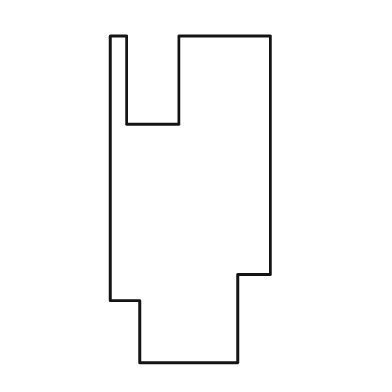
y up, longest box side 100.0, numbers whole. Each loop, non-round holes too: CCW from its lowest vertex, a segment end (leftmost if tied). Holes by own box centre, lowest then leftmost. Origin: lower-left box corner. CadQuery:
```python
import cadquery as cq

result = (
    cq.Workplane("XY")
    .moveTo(9.0, 0.0)
    .lineTo(39.0, 0.0)
    .lineTo(39.0, 27.0)
    .lineTo(49.0, 27.0)
    .lineTo(49.0, 100.0)
    .lineTo(21.0, 100.0)
    .lineTo(21.0, 73.0)
    .lineTo(5.0, 73.0)
    .lineTo(5.0, 100.0)
    .lineTo(0.0, 100.0)
    .lineTo(0.0, 19.0)
    .lineTo(9.0, 19.0)
    .close()
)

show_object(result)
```